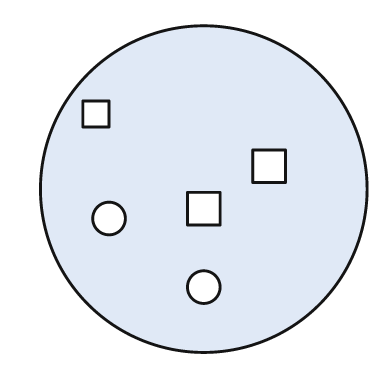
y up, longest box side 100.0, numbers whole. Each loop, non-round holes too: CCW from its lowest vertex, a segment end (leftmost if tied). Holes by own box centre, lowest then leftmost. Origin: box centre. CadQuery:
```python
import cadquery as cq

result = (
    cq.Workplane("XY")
    .moveTo(0.0, 0.0)
    .circle(50.0)
    .moveTo(0.0, -30.0)
    .circle(5.0)
    .moveTo(-29.0, -9.0)
    .circle(5.0)
    .moveTo(-5.0, -11.0)
    .lineTo(5.0, -11.0)
    .lineTo(5.0, -1.0)
    .lineTo(-5.0, -1.0)
    .close()
    .moveTo(15.0, 2.0)
    .lineTo(25.0, 2.0)
    .lineTo(25.0, 12.0)
    .lineTo(15.0, 12.0)
    .close()
    .moveTo(-37.0, 19.0)
    .lineTo(-29.0, 19.0)
    .lineTo(-29.0, 27.0)
    .lineTo(-37.0, 27.0)
    .close()
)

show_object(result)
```